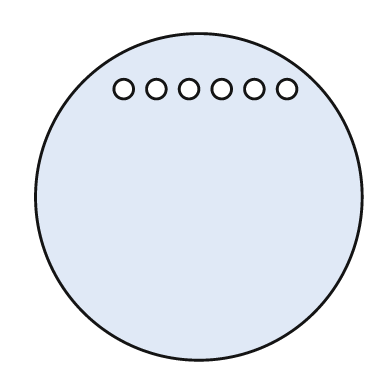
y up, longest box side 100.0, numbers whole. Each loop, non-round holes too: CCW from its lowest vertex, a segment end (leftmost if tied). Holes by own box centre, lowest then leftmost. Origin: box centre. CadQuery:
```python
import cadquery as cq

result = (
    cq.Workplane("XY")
    .moveTo(0.0, 0.0)
    .circle(50.0)
    .moveTo(-23.0, 33.0)
    .circle(3.0)
    .moveTo(-13.0, 33.0)
    .circle(3.0)
    .moveTo(-3.0, 33.0)
    .circle(3.0)
    .moveTo(7.0, 33.0)
    .circle(3.0)
    .moveTo(17.0, 33.0)
    .circle(3.0)
    .moveTo(27.0, 33.0)
    .circle(3.0)
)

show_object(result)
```